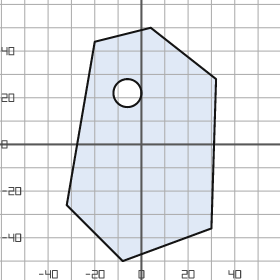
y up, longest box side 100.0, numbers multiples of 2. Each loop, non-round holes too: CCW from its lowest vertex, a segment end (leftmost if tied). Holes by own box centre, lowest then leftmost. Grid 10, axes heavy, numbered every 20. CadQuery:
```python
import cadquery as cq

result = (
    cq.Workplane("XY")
    .moveTo(-8.0, -50.0)
    .lineTo(30.0, -36.0)
    .lineTo(32.0, 28.0)
    .lineTo(4.0, 50.0)
    .lineTo(-20.0, 44.0)
    .lineTo(-32.0, -26.0)
    .close()
    .moveTo(-6.0, 22.0)
    .circle(6.0)
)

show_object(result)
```